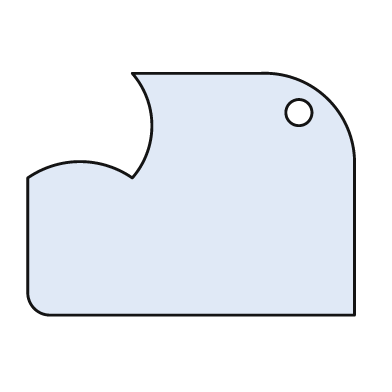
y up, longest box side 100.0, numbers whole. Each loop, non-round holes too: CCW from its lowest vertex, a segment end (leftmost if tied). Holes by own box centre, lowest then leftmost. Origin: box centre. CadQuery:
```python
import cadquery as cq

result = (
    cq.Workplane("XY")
    .moveTo(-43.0, -37.0)
    .lineTo(50.0, -37.0)
    .lineTo(50.0, 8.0)
    .threePointArc((42.0, 29.0), (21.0, 37.0))
    .lineTo(-18.0, 37.0)
    .threePointArc((-12.0, 21.0), (-18.0, 5.0))
    .threePointArc((-34.0, 10.0), (-50.0, 5.0))
    .lineTo(-50.0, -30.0)
    .threePointArc((-48.0, -35.0), (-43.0, -37.0))
    .close()
    .moveTo(33.0, 25.0)
    .circle(4.0)
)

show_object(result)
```